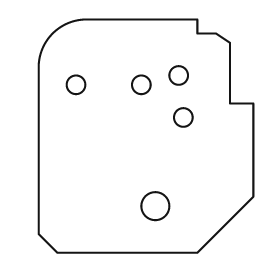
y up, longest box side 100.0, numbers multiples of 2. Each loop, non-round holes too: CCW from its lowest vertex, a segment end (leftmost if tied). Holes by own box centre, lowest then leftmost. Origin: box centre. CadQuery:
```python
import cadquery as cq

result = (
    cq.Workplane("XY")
    .moveTo(-38.0, -50.0)
    .lineTo(22.0, -50.0)
    .lineTo(46.0, -26.0)
    .lineTo(46.0, 14.0)
    .lineTo(36.0, 14.0)
    .lineTo(36.0, 40.0)
    .lineTo(30.0, 44.0)
    .lineTo(22.0, 44.0)
    .lineTo(22.0, 50.0)
    .lineTo(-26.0, 50.0)
    .threePointArc((-40.0, 44.0), (-46.0, 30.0))
    .lineTo(-46.0, -42.0)
    .close()
    .moveTo(4.0, -30.0)
    .circle(6.0)
    .moveTo(16.0, 8.0)
    .circle(4.0)
    .moveTo(-30.0, 22.0)
    .circle(4.0)
    .moveTo(-2.0, 22.0)
    .circle(4.0)
    .moveTo(14.0, 26.0)
    .circle(4.0)
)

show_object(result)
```